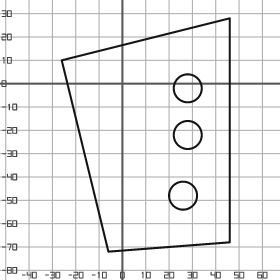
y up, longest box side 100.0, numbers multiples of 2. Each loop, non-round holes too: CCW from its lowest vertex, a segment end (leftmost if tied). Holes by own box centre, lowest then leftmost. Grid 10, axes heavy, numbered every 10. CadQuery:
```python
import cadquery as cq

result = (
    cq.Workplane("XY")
    .moveTo(-6.0, -72.0)
    .lineTo(46.0, -68.0)
    .lineTo(46.0, 28.0)
    .lineTo(-26.0, 10.0)
    .close()
    .moveTo(26.0, -48.0)
    .circle(6.0)
    .moveTo(28.0, -22.0)
    .circle(6.0)
    .moveTo(28.0, -2.0)
    .circle(6.0)
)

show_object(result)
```